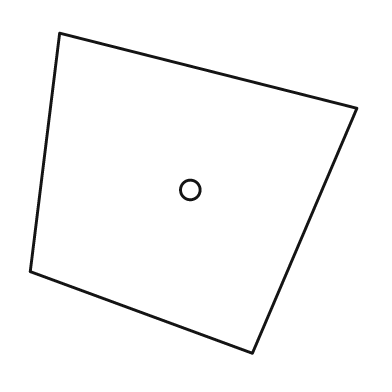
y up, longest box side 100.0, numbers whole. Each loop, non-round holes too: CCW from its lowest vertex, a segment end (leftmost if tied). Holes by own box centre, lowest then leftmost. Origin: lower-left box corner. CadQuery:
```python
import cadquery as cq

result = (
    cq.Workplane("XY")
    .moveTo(68.0, 0.0)
    .lineTo(100.0, 75.0)
    .lineTo(9.0, 98.0)
    .lineTo(0.0, 25.0)
    .close()
    .moveTo(49.0, 50.0)
    .circle(3.0)
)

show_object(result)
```